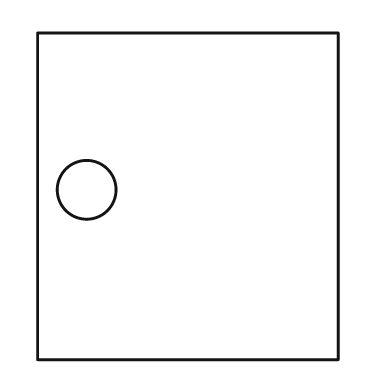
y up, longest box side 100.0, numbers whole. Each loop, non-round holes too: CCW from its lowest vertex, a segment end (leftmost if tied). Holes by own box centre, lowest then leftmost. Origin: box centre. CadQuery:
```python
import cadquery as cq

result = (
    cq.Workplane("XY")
    .moveTo(-46.0, -50.0)
    .lineTo(46.0, -50.0)
    .lineTo(46.0, 50.0)
    .lineTo(-46.0, 50.0)
    .close()
    .moveTo(-31.0, 2.0)
    .circle(9.0)
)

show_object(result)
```